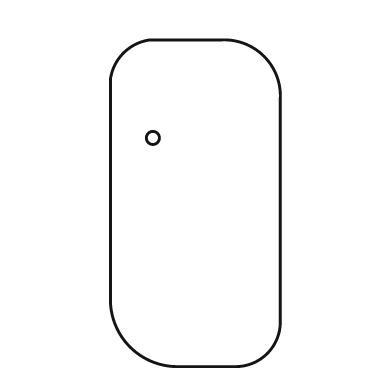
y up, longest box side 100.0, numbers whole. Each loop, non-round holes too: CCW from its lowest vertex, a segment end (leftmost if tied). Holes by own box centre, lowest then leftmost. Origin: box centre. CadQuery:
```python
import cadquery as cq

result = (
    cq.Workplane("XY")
    .moveTo(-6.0, -50.0)
    .lineTo(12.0, -50.0)
    .threePointArc((22.0, -46.0), (26.0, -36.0))
    .lineTo(26.0, 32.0)
    .threePointArc((21.0, 45.0), (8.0, 50.0))
    .lineTo(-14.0, 50.0)
    .threePointArc((-22.0, 46.0), (-26.0, 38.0))
    .lineTo(-26.0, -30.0)
    .threePointArc((-20.0, -44.0), (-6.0, -50.0))
    .close()
    .moveTo(-13.0, 20.0)
    .circle(2.0)
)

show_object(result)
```